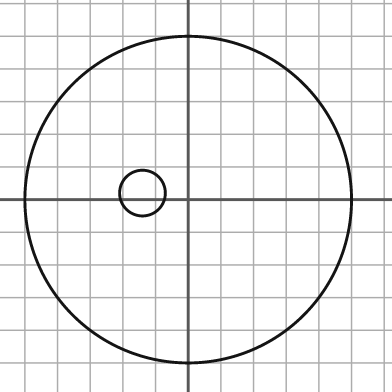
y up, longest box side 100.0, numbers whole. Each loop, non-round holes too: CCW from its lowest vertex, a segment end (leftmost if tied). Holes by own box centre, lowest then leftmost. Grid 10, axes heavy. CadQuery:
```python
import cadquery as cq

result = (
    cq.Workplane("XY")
    .moveTo(0.0, 0.0)
    .circle(50.0)
    .moveTo(-14.0, 2.0)
    .circle(7.0)
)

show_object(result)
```